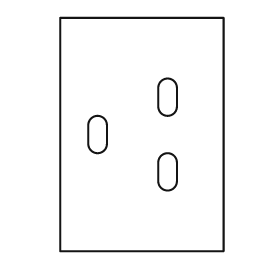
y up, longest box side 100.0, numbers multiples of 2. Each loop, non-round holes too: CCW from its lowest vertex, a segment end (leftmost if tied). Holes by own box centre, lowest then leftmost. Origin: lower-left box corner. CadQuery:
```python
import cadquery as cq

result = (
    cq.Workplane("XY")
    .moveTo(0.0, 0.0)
    .lineTo(70.0, 0.0)
    .lineTo(70.0, 100.0)
    .lineTo(0.0, 100.0)
    .close()
    .moveTo(42.0, 30.0)
    .threePointArc((46.0, 26.0), (50.0, 30.0))
    .lineTo(50.0, 38.0)
    .threePointArc((46.0, 42.0), (42.0, 38.0))
    .close()
    .moveTo(12.0, 46.0)
    .threePointArc((16.0, 42.0), (20.0, 46.0))
    .lineTo(20.0, 54.0)
    .threePointArc((16.0, 58.0), (12.0, 54.0))
    .close()
    .moveTo(42.0, 62.0)
    .threePointArc((46.0, 58.0), (50.0, 62.0))
    .lineTo(50.0, 70.0)
    .threePointArc((46.0, 74.0), (42.0, 70.0))
    .close()
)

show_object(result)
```